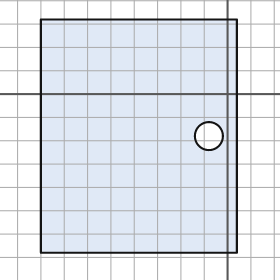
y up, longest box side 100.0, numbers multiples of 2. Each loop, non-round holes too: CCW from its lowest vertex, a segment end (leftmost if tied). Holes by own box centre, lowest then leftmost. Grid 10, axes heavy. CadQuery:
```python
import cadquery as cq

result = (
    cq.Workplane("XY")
    .moveTo(-80.0, -68.0)
    .lineTo(4.0, -68.0)
    .lineTo(4.0, 32.0)
    .lineTo(-80.0, 32.0)
    .close()
    .moveTo(-8.0, -18.0)
    .circle(6.0)
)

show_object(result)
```